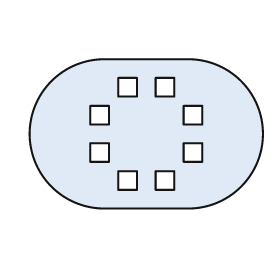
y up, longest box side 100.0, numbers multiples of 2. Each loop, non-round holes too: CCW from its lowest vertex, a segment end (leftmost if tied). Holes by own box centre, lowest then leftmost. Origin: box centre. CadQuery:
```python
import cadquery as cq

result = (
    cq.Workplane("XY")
    .moveTo(-18.0, -32.0)
    .lineTo(18.0, -32.0)
    .threePointArc((50.0, 0.0), (18.0, 32.0))
    .lineTo(-18.0, 32.0)
    .threePointArc((-50.0, 0.0), (-18.0, -32.0))
    .close()
    .moveTo(-12.0, -24.0)
    .lineTo(-4.0, -24.0)
    .lineTo(-4.0, -16.0)
    .lineTo(-12.0, -16.0)
    .close()
    .moveTo(4.0, -24.0)
    .lineTo(12.0, -24.0)
    .lineTo(12.0, -16.0)
    .lineTo(4.0, -16.0)
    .close()
    .moveTo(-24.0, -12.0)
    .lineTo(-16.0, -12.0)
    .lineTo(-16.0, -4.0)
    .lineTo(-24.0, -4.0)
    .close()
    .moveTo(16.0, -12.0)
    .lineTo(24.0, -12.0)
    .lineTo(24.0, -4.0)
    .lineTo(16.0, -4.0)
    .close()
    .moveTo(-24.0, 4.0)
    .lineTo(-16.0, 4.0)
    .lineTo(-16.0, 12.0)
    .lineTo(-24.0, 12.0)
    .close()
    .moveTo(16.0, 4.0)
    .lineTo(24.0, 4.0)
    .lineTo(24.0, 12.0)
    .lineTo(16.0, 12.0)
    .close()
    .moveTo(-12.0, 16.0)
    .lineTo(-4.0, 16.0)
    .lineTo(-4.0, 24.0)
    .lineTo(-12.0, 24.0)
    .close()
    .moveTo(4.0, 16.0)
    .lineTo(12.0, 16.0)
    .lineTo(12.0, 24.0)
    .lineTo(4.0, 24.0)
    .close()
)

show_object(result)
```